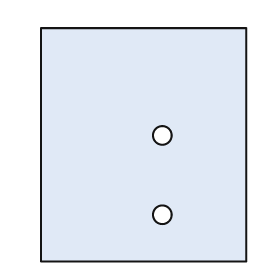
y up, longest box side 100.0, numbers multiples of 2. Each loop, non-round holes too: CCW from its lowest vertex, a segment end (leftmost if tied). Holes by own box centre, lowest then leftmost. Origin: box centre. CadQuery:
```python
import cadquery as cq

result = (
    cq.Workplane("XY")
    .moveTo(-44.0, -50.0)
    .lineTo(44.0, -50.0)
    .lineTo(44.0, 50.0)
    .lineTo(-44.0, 50.0)
    .close()
    .moveTo(8.0, -30.0)
    .circle(4.0)
    .moveTo(8.0, 4.0)
    .circle(4.0)
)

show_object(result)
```